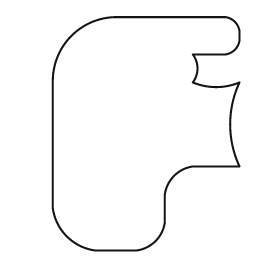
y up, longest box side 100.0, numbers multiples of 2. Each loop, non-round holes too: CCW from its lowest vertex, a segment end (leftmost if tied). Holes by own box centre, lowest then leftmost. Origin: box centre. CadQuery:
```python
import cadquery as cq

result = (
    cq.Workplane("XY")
    .moveTo(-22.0, -50.0)
    .lineTo(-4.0, -50.0)
    .threePointArc((4.0, -46.0), (8.0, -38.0))
    .lineTo(8.0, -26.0)
    .threePointArc((12.0, -18.0), (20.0, -14.0))
    .lineTo(40.0, -14.0)
    .threePointArc((36.0, 4.0), (40.0, 22.0))
    .threePointArc((30.0, 20.0), (20.0, 22.0))
    .threePointArc((22.0, 28.0), (20.0, 34.0))
    .lineTo(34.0, 34.0)
    .threePointArc((38.0, 36.0), (40.0, 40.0))
    .lineTo(40.0, 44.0)
    .threePointArc((38.0, 48.0), (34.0, 50.0))
    .lineTo(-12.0, 50.0)
    .threePointArc((-32.0, 42.0), (-40.0, 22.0))
    .lineTo(-40.0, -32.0)
    .threePointArc((-34.0, -44.0), (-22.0, -50.0))
    .close()
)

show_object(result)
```